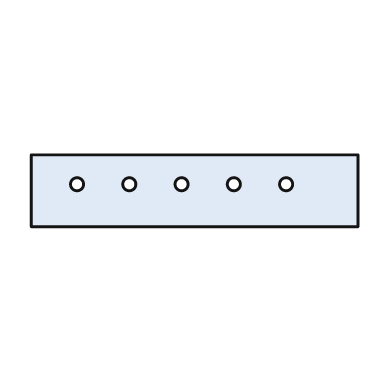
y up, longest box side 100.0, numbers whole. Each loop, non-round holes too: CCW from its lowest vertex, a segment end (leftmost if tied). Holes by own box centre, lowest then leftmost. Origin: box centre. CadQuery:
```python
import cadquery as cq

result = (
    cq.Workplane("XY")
    .moveTo(-50.0, -11.0)
    .lineTo(50.0, -11.0)
    .lineTo(50.0, 11.0)
    .lineTo(-50.0, 11.0)
    .close()
    .moveTo(-36.0, 2.0)
    .circle(2.0)
    .moveTo(-20.0, 2.0)
    .circle(2.0)
    .moveTo(-4.0, 2.0)
    .circle(2.0)
    .moveTo(12.0, 2.0)
    .circle(2.0)
    .moveTo(28.0, 2.0)
    .circle(2.0)
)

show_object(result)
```